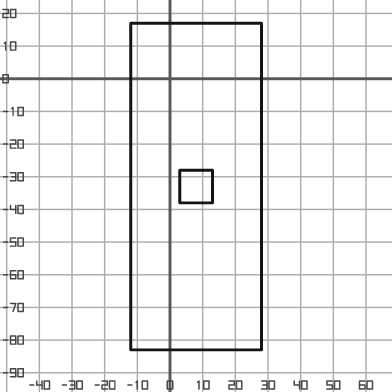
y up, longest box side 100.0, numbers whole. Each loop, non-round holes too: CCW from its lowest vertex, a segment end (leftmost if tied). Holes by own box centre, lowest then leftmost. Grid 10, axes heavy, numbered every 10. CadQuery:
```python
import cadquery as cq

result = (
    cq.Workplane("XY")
    .moveTo(-12.0, -83.0)
    .lineTo(28.0, -83.0)
    .lineTo(28.0, 17.0)
    .lineTo(-12.0, 17.0)
    .close()
    .moveTo(3.0, -38.0)
    .lineTo(13.0, -38.0)
    .lineTo(13.0, -28.0)
    .lineTo(3.0, -28.0)
    .close()
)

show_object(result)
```